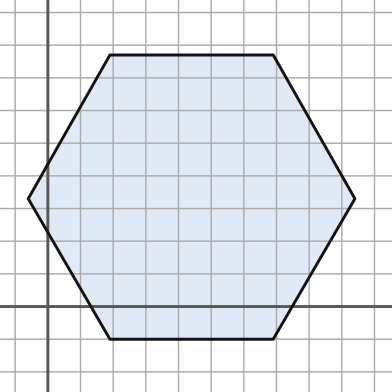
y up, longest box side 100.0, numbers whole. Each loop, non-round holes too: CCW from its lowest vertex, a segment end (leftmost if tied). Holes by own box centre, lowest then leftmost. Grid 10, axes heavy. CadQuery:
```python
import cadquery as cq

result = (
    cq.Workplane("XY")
    .moveTo(19.0, -10.0)
    .lineTo(69.0, -10.0)
    .lineTo(94.0, 33.0)
    .lineTo(69.0, 77.0)
    .lineTo(19.0, 77.0)
    .lineTo(-6.0, 33.0)
    .close()
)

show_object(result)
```